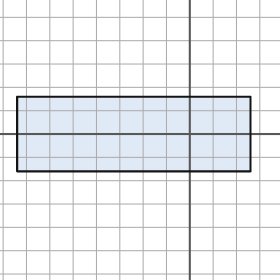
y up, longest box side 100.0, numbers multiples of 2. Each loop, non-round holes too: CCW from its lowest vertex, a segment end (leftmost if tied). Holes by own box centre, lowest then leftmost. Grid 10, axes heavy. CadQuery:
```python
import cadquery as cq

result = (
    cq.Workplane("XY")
    .moveTo(-74.0, -16.0)
    .lineTo(26.0, -16.0)
    .lineTo(26.0, 16.0)
    .lineTo(-74.0, 16.0)
    .close()
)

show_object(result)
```